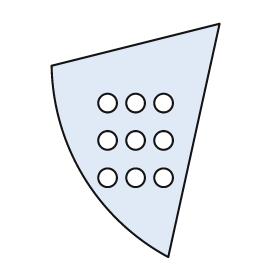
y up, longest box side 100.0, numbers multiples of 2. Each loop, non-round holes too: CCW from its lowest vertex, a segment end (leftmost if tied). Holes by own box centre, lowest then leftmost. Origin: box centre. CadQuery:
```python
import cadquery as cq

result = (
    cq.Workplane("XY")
    .moveTo(14.0, -50.0)
    .lineTo(36.0, 50.0)
    .lineTo(-36.0, 32.0)
    .threePointArc((-22.0, -16.0), (14.0, -50.0))
    .close()
    .moveTo(-12.0, -16.0)
    .circle(4.0)
    .moveTo(0.0, -16.0)
    .circle(4.0)
    .moveTo(12.0, -16.0)
    .circle(4.0)
    .moveTo(-12.0, 0.0)
    .circle(4.0)
    .moveTo(0.0, 0.0)
    .circle(4.0)
    .moveTo(12.0, 0.0)
    .circle(4.0)
    .moveTo(-12.0, 16.0)
    .circle(4.0)
    .moveTo(0.0, 16.0)
    .circle(4.0)
    .moveTo(12.0, 16.0)
    .circle(4.0)
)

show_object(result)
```